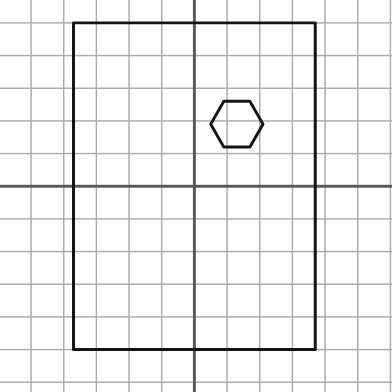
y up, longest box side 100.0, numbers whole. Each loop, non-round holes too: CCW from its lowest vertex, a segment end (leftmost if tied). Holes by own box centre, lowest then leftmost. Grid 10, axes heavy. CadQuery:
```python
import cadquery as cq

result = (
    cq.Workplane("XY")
    .moveTo(-37.0, -50.0)
    .lineTo(37.0, -50.0)
    .lineTo(37.0, 50.0)
    .lineTo(-37.0, 50.0)
    .close()
    .moveTo(9.0, 12.0)
    .lineTo(17.0, 12.0)
    .lineTo(21.0, 19.0)
    .lineTo(17.0, 26.0)
    .lineTo(9.0, 26.0)
    .lineTo(5.0, 19.0)
    .close()
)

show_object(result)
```